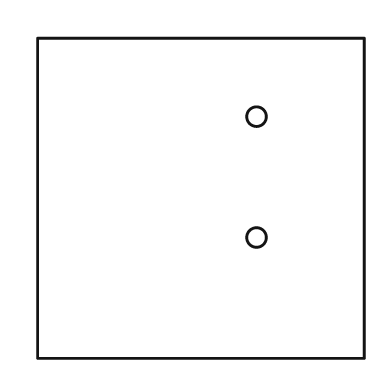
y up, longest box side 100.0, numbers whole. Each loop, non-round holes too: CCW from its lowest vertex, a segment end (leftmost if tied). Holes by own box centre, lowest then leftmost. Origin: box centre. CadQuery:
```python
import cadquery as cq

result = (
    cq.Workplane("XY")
    .moveTo(-50.0, -49.0)
    .lineTo(50.0, -49.0)
    .lineTo(50.0, 49.0)
    .lineTo(-50.0, 49.0)
    .close()
    .moveTo(17.0, -12.0)
    .circle(3.0)
    .moveTo(17.0, 25.0)
    .circle(3.0)
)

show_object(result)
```